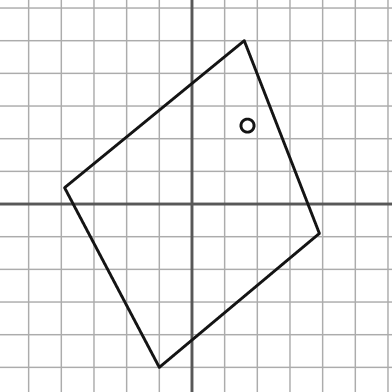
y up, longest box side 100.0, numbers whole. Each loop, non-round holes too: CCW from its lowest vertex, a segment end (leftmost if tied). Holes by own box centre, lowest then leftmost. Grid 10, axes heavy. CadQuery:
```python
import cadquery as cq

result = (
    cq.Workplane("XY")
    .moveTo(-10.0, -50.0)
    .lineTo(39.0, -9.0)
    .lineTo(16.0, 50.0)
    .lineTo(-39.0, 5.0)
    .close()
    .moveTo(17.0, 24.0)
    .circle(2.0)
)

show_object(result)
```